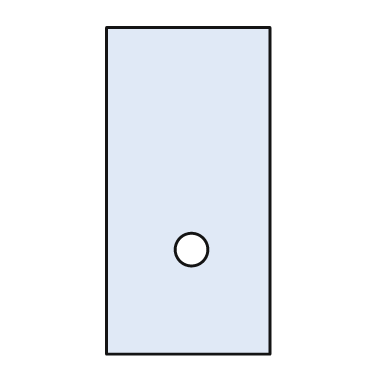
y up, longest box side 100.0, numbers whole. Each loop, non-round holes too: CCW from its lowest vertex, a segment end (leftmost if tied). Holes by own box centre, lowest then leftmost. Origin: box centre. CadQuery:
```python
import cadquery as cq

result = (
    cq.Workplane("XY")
    .moveTo(-25.0, -50.0)
    .lineTo(25.0, -50.0)
    .lineTo(25.0, 50.0)
    .lineTo(-25.0, 50.0)
    .close()
    .moveTo(1.0, -18.0)
    .circle(5.0)
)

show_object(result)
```